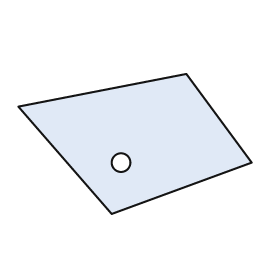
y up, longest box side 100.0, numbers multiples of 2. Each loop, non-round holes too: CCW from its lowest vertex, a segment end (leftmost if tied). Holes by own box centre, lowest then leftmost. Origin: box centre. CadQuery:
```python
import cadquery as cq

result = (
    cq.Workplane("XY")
    .moveTo(-10.0, -30.0)
    .lineTo(50.0, -8.0)
    .lineTo(22.0, 30.0)
    .lineTo(-50.0, 16.0)
    .close()
    .moveTo(-6.0, -8.0)
    .circle(4.0)
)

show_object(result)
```